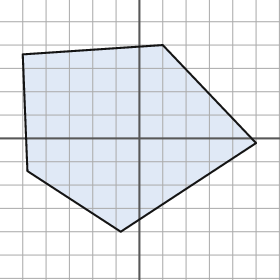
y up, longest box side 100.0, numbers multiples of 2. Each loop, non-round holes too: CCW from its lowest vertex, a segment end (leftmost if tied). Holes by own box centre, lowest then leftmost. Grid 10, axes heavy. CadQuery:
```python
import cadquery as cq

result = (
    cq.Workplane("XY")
    .moveTo(-8.0, -40.0)
    .lineTo(50.0, -2.0)
    .lineTo(10.0, 40.0)
    .lineTo(-50.0, 36.0)
    .lineTo(-48.0, -14.0)
    .close()
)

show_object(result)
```